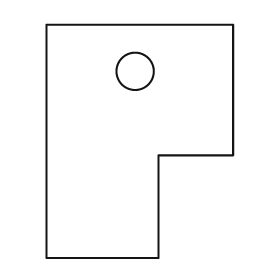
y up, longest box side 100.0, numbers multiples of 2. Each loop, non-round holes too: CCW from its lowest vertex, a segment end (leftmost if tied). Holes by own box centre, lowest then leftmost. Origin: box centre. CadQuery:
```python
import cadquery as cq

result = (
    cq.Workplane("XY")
    .moveTo(-40.0, -50.0)
    .lineTo(8.0, -50.0)
    .lineTo(8.0, -6.0)
    .lineTo(40.0, -6.0)
    .lineTo(40.0, 50.0)
    .lineTo(-40.0, 50.0)
    .close()
    .moveTo(-2.0, 30.0)
    .circle(8.0)
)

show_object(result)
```